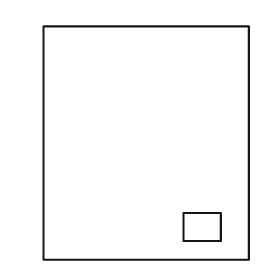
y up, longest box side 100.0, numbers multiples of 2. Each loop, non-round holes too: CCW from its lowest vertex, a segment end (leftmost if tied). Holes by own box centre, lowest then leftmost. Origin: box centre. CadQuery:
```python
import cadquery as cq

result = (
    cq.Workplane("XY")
    .moveTo(-44.0, -50.0)
    .lineTo(44.0, -50.0)
    .lineTo(44.0, 50.0)
    .lineTo(-44.0, 50.0)
    .close()
    .moveTo(16.0, -42.0)
    .lineTo(32.0, -42.0)
    .lineTo(32.0, -30.0)
    .lineTo(16.0, -30.0)
    .close()
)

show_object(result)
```